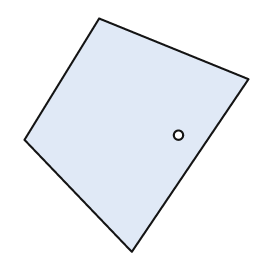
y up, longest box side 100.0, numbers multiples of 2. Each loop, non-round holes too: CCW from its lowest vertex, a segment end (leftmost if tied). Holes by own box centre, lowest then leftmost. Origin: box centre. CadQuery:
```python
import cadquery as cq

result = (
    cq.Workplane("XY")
    .moveTo(-2.0, -50.0)
    .lineTo(48.0, 24.0)
    .lineTo(-16.0, 50.0)
    .lineTo(-48.0, -2.0)
    .close()
    .moveTo(18.0, 0.0)
    .circle(2.0)
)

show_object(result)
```